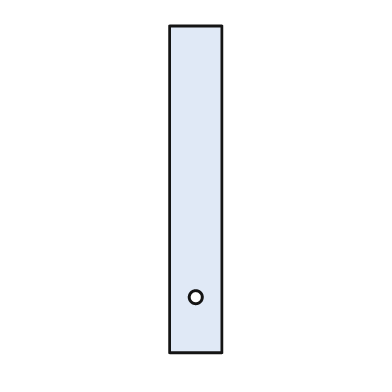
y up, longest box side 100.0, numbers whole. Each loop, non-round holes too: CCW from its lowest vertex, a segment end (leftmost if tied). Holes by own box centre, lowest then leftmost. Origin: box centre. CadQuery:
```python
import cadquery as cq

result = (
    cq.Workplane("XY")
    .moveTo(-8.0, -50.0)
    .lineTo(8.0, -50.0)
    .lineTo(8.0, 50.0)
    .lineTo(-8.0, 50.0)
    .close()
    .moveTo(0.0, -33.0)
    .circle(2.0)
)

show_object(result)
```